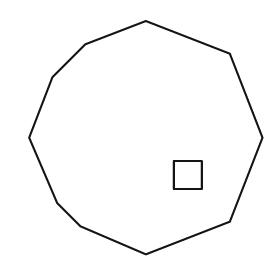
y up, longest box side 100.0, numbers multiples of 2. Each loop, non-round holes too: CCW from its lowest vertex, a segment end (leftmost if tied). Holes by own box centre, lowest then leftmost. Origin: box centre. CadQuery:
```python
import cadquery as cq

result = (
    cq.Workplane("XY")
    .moveTo(0.0, -50.0)
    .lineTo(36.0, -36.0)
    .lineTo(50.0, 0.0)
    .lineTo(36.0, 36.0)
    .lineTo(0.0, 50.0)
    .lineTo(-26.0, 40.0)
    .lineTo(-40.0, 26.0)
    .lineTo(-50.0, 0.0)
    .lineTo(-38.0, -28.0)
    .lineTo(-28.0, -38.0)
    .close()
    .moveTo(12.0, -22.0)
    .lineTo(24.0, -22.0)
    .lineTo(24.0, -10.0)
    .lineTo(12.0, -10.0)
    .close()
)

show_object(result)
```